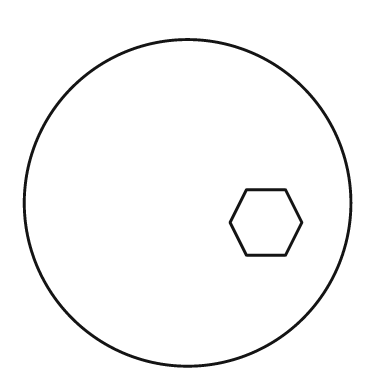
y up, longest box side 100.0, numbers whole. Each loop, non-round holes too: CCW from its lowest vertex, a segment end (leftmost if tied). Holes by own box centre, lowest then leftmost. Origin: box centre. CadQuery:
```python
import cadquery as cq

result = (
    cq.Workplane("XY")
    .moveTo(0.0, 0.0)
    .circle(50.0)
    .moveTo(18.0, -16.0)
    .lineTo(30.0, -16.0)
    .lineTo(35.0, -6.0)
    .lineTo(30.0, 4.0)
    .lineTo(18.0, 4.0)
    .lineTo(13.0, -6.0)
    .close()
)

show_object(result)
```